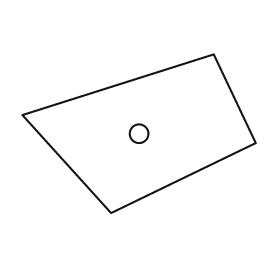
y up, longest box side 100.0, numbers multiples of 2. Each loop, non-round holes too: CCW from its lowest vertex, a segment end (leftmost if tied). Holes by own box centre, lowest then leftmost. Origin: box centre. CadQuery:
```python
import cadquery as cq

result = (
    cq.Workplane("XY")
    .moveTo(-12.0, -34.0)
    .lineTo(50.0, -4.0)
    .lineTo(32.0, 34.0)
    .lineTo(-50.0, 8.0)
    .close()
    .moveTo(0.0, 0.0)
    .circle(4.0)
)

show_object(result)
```